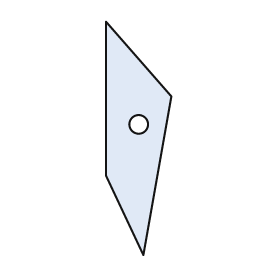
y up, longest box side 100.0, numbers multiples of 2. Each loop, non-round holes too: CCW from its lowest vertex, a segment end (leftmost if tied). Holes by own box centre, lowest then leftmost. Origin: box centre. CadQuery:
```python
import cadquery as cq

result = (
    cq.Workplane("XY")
    .moveTo(2.0, -50.0)
    .lineTo(14.0, 18.0)
    .lineTo(-14.0, 50.0)
    .lineTo(-14.0, -16.0)
    .close()
    .moveTo(0.0, 6.0)
    .circle(4.0)
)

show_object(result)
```